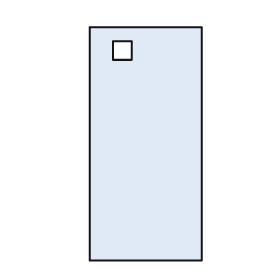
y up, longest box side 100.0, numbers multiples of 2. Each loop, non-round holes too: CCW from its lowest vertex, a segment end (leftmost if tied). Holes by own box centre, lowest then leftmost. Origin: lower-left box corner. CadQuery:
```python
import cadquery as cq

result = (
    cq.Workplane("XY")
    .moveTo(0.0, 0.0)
    .lineTo(48.0, 0.0)
    .lineTo(48.0, 100.0)
    .lineTo(0.0, 100.0)
    .close()
    .moveTo(10.0, 86.0)
    .lineTo(18.0, 86.0)
    .lineTo(18.0, 94.0)
    .lineTo(10.0, 94.0)
    .close()
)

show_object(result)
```